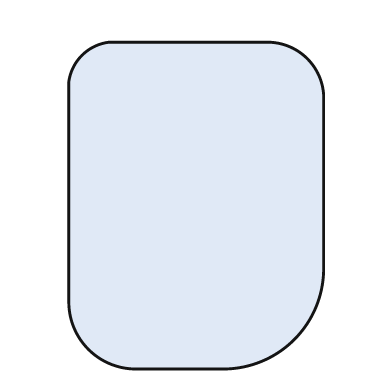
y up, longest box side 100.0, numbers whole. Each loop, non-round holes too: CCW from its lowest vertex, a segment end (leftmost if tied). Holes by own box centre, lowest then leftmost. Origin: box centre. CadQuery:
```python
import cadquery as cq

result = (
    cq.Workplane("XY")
    .moveTo(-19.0, -50.0)
    .lineTo(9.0, -50.0)
    .threePointArc((30.0, -41.0), (39.0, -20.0))
    .lineTo(39.0, 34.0)
    .threePointArc((34.0, 45.0), (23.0, 50.0))
    .lineTo(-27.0, 50.0)
    .threePointArc((-35.0, 46.0), (-39.0, 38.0))
    .lineTo(-39.0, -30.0)
    .threePointArc((-33.0, -44.0), (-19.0, -50.0))
    .close()
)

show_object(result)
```